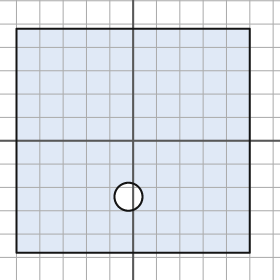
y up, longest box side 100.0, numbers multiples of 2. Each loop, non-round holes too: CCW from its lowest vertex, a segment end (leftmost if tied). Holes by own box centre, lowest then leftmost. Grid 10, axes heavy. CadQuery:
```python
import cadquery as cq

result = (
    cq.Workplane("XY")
    .moveTo(-50.0, -48.0)
    .lineTo(50.0, -48.0)
    .lineTo(50.0, 48.0)
    .lineTo(-50.0, 48.0)
    .close()
    .moveTo(-2.0, -24.0)
    .circle(6.0)
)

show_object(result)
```